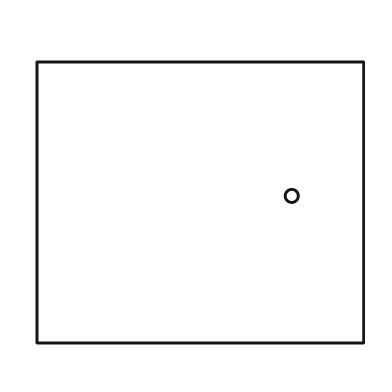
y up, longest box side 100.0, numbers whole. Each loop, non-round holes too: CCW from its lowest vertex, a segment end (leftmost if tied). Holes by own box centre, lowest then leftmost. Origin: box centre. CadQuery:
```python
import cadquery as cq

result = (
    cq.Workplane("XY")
    .moveTo(-50.0, -43.0)
    .lineTo(50.0, -43.0)
    .lineTo(50.0, 43.0)
    .lineTo(-50.0, 43.0)
    .close()
    .moveTo(28.0, 2.0)
    .circle(2.0)
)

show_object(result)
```